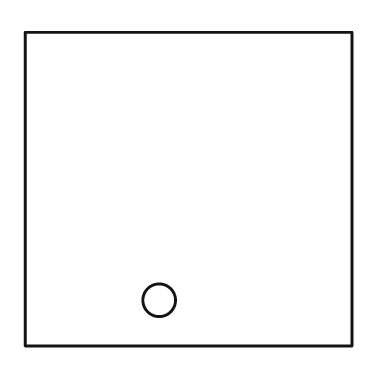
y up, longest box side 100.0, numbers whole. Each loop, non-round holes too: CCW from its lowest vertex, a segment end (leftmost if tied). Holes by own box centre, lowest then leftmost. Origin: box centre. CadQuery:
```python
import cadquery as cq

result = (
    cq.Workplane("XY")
    .moveTo(-50.0, -48.0)
    .lineTo(50.0, -48.0)
    .lineTo(50.0, 48.0)
    .lineTo(-50.0, 48.0)
    .close()
    .moveTo(-9.0, -34.0)
    .circle(5.0)
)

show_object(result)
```